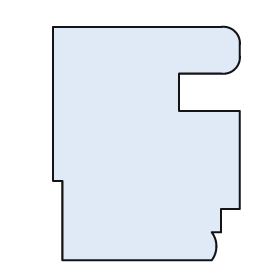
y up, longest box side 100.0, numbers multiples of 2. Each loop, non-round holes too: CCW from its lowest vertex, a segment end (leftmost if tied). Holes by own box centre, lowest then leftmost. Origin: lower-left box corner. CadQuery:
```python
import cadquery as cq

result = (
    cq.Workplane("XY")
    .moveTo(4.0, 0.0)
    .lineTo(68.0, 0.0)
    .threePointArc((70.0, 6.0), (68.0, 12.0))
    .lineTo(72.0, 12.0)
    .lineTo(72.0, 22.0)
    .lineTo(80.0, 22.0)
    .lineTo(80.0, 64.0)
    .lineTo(54.0, 64.0)
    .lineTo(54.0, 80.0)
    .lineTo(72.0, 80.0)
    .threePointArc((78.0, 82.0), (80.0, 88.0))
    .lineTo(80.0, 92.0)
    .threePointArc((78.0, 98.0), (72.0, 100.0))
    .lineTo(0.0, 100.0)
    .lineTo(0.0, 34.0)
    .lineTo(4.0, 34.0)
    .close()
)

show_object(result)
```